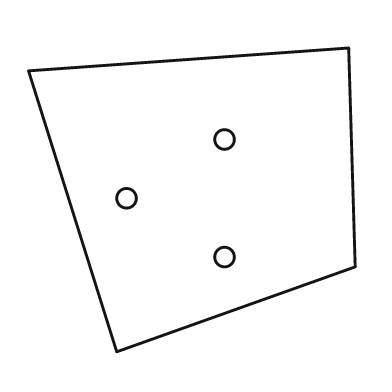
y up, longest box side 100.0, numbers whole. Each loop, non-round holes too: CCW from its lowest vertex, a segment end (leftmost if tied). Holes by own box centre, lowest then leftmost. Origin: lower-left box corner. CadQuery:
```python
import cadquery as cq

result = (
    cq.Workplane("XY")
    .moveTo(27.0, 0.0)
    .lineTo(100.0, 26.0)
    .lineTo(98.0, 93.0)
    .lineTo(0.0, 86.0)
    .close()
    .moveTo(60.0, 29.0)
    .circle(3.0)
    .moveTo(30.0, 47.0)
    .circle(3.0)
    .moveTo(60.0, 65.0)
    .circle(3.0)
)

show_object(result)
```